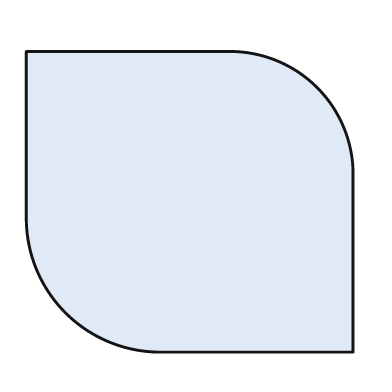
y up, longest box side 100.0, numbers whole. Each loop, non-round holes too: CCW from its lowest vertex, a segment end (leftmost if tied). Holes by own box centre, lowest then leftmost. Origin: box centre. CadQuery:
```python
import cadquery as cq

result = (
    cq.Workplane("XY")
    .moveTo(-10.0, -46.0)
    .lineTo(50.0, -46.0)
    .lineTo(50.0, 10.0)
    .threePointArc((39.0, 35.0), (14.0, 46.0))
    .lineTo(-50.0, 46.0)
    .lineTo(-50.0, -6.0)
    .threePointArc((-38.0, -34.0), (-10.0, -46.0))
    .close()
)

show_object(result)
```